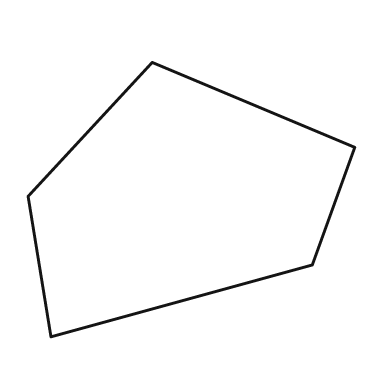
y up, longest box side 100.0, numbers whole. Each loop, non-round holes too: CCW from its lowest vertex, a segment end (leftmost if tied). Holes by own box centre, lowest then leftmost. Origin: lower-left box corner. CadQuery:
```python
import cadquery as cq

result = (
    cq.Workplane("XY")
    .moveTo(7.0, 0.0)
    .lineTo(87.0, 22.0)
    .lineTo(100.0, 58.0)
    .lineTo(38.0, 84.0)
    .lineTo(0.0, 43.0)
    .close()
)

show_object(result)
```